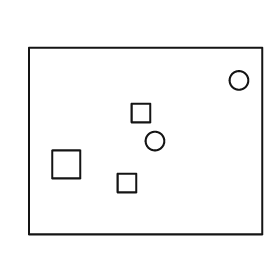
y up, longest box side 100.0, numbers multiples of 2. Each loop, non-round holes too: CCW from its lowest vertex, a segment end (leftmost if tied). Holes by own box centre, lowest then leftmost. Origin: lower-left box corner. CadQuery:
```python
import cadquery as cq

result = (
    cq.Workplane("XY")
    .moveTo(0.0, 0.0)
    .lineTo(100.0, 0.0)
    .lineTo(100.0, 80.0)
    .lineTo(0.0, 80.0)
    .close()
    .moveTo(38.0, 18.0)
    .lineTo(46.0, 18.0)
    .lineTo(46.0, 26.0)
    .lineTo(38.0, 26.0)
    .close()
    .moveTo(10.0, 24.0)
    .lineTo(22.0, 24.0)
    .lineTo(22.0, 36.0)
    .lineTo(10.0, 36.0)
    .close()
    .moveTo(54.0, 40.0)
    .circle(4.0)
    .moveTo(44.0, 48.0)
    .lineTo(52.0, 48.0)
    .lineTo(52.0, 56.0)
    .lineTo(44.0, 56.0)
    .close()
    .moveTo(90.0, 66.0)
    .circle(4.0)
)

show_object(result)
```